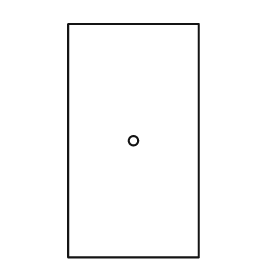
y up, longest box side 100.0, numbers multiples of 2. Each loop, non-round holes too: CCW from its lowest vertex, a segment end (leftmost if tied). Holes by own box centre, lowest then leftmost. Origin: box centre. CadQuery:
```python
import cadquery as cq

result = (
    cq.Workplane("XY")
    .moveTo(-28.0, -50.0)
    .lineTo(28.0, -50.0)
    .lineTo(28.0, 50.0)
    .lineTo(-28.0, 50.0)
    .close()
    .moveTo(0.0, 0.0)
    .circle(2.0)
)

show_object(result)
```